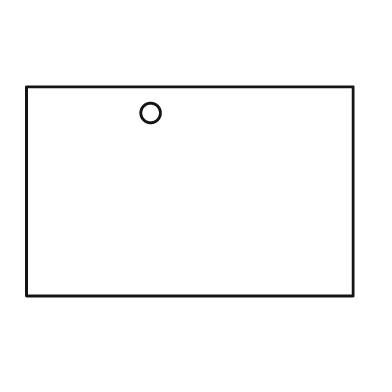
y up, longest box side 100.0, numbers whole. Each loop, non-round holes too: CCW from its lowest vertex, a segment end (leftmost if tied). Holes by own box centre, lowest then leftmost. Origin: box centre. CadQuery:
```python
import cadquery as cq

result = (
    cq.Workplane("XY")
    .moveTo(-50.0, -32.0)
    .lineTo(50.0, -32.0)
    .lineTo(50.0, 32.0)
    .lineTo(-50.0, 32.0)
    .close()
    .moveTo(-12.0, 24.0)
    .circle(3.0)
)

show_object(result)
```